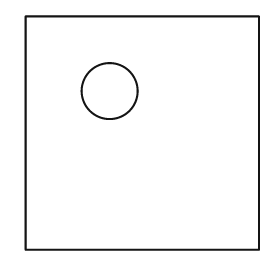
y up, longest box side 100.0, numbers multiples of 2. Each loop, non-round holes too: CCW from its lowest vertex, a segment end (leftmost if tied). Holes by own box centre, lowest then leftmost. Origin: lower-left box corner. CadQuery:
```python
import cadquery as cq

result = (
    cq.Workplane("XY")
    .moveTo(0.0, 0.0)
    .lineTo(100.0, 0.0)
    .lineTo(100.0, 100.0)
    .lineTo(0.0, 100.0)
    .close()
    .moveTo(36.0, 68.0)
    .circle(12.0)
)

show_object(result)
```